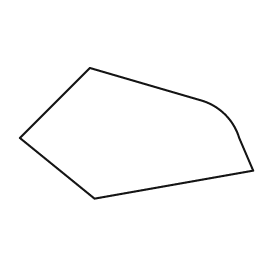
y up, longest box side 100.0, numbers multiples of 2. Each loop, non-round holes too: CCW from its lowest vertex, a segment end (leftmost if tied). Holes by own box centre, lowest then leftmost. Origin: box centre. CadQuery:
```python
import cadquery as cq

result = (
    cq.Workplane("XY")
    .moveTo(-18.0, -28.0)
    .lineTo(50.0, -16.0)
    .lineTo(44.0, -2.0)
    .threePointArc((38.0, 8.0), (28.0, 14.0))
    .lineTo(-20.0, 28.0)
    .lineTo(-50.0, -2.0)
    .close()
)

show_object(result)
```